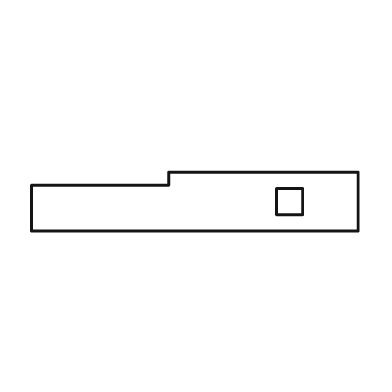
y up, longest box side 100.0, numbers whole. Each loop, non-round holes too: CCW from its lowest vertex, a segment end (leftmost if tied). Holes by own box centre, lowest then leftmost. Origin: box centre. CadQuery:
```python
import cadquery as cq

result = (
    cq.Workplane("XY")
    .moveTo(-50.0, -9.0)
    .lineTo(50.0, -9.0)
    .lineTo(50.0, 9.0)
    .lineTo(-8.0, 9.0)
    .lineTo(-8.0, 5.0)
    .lineTo(-50.0, 5.0)
    .close()
    .moveTo(25.0, -4.0)
    .lineTo(33.0, -4.0)
    .lineTo(33.0, 4.0)
    .lineTo(25.0, 4.0)
    .close()
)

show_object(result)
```